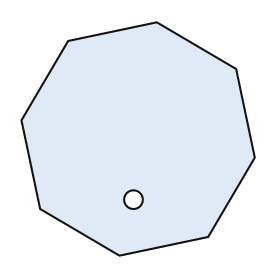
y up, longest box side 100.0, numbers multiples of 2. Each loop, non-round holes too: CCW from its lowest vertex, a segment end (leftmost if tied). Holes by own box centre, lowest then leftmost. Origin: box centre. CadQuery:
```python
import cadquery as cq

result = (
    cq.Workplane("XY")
    .moveTo(-8.0, -50.0)
    .lineTo(30.0, -42.0)
    .lineTo(50.0, -8.0)
    .lineTo(42.0, 30.0)
    .lineTo(8.0, 50.0)
    .lineTo(-30.0, 42.0)
    .lineTo(-50.0, 8.0)
    .lineTo(-42.0, -30.0)
    .close()
    .moveTo(-2.0, -26.0)
    .circle(4.0)
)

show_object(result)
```